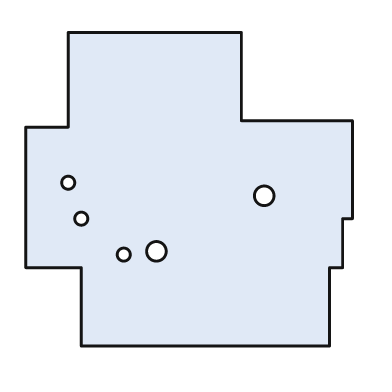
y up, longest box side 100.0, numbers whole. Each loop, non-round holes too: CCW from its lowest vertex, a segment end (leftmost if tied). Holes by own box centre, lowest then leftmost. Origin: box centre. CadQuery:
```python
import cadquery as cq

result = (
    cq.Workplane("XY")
    .moveTo(-33.0, -48.0)
    .lineTo(43.0, -48.0)
    .lineTo(43.0, -24.0)
    .lineTo(47.0, -24.0)
    .lineTo(47.0, -9.0)
    .lineTo(50.0, -9.0)
    .lineTo(50.0, 21.0)
    .lineTo(16.0, 21.0)
    .lineTo(16.0, 48.0)
    .lineTo(-37.0, 48.0)
    .lineTo(-37.0, 19.0)
    .lineTo(-50.0, 19.0)
    .lineTo(-50.0, -24.0)
    .lineTo(-33.0, -24.0)
    .close()
    .moveTo(-20.0, -20.0)
    .circle(2.0)
    .moveTo(-10.0, -19.0)
    .circle(3.0)
    .moveTo(-33.0, -9.0)
    .circle(2.0)
    .moveTo(23.0, -2.0)
    .circle(3.0)
    .moveTo(-37.0, 2.0)
    .circle(2.0)
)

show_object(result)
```